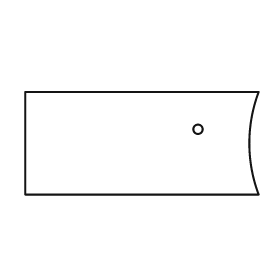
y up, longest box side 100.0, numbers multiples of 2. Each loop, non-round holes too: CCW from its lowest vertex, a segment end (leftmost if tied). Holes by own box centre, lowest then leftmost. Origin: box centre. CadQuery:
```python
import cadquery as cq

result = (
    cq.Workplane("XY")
    .moveTo(-50.0, -22.0)
    .lineTo(50.0, -22.0)
    .threePointArc((46.0, 0.0), (50.0, 22.0))
    .lineTo(-50.0, 22.0)
    .close()
    .moveTo(24.0, 6.0)
    .circle(2.0)
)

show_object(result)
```